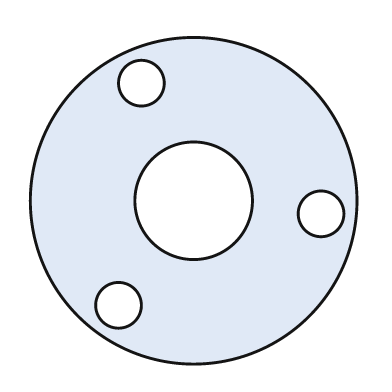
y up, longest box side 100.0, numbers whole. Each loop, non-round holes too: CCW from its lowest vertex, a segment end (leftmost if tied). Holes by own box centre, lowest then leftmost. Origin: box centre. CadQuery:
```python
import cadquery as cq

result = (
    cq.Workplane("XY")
    .moveTo(0.0, 0.0)
    .circle(50.0)
    .moveTo(-23.0, -32.0)
    .circle(7.0)
    .moveTo(39.0, -4.0)
    .circle(7.0)
    .moveTo(0.0, 0.0)
    .circle(18.0)
    .moveTo(-16.0, 36.0)
    .circle(7.0)
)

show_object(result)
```